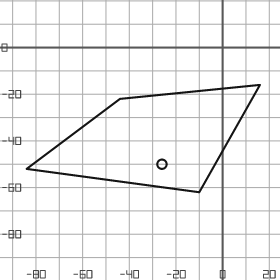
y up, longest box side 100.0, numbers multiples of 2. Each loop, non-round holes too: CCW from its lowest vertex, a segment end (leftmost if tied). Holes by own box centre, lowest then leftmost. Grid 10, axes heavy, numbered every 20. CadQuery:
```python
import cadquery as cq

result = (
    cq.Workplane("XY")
    .moveTo(-10.0, -62.0)
    .lineTo(16.0, -16.0)
    .lineTo(-44.0, -22.0)
    .lineTo(-84.0, -52.0)
    .close()
    .moveTo(-26.0, -50.0)
    .circle(2.0)
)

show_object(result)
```